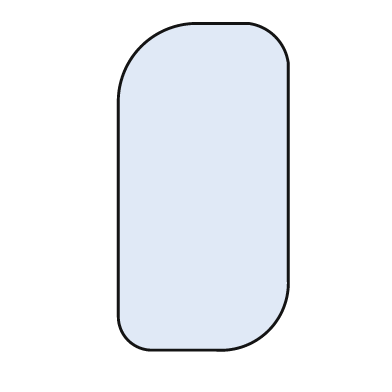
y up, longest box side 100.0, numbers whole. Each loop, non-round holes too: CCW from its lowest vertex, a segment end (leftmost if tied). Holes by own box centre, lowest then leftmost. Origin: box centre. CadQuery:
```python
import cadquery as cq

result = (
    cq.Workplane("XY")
    .moveTo(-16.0, -50.0)
    .lineTo(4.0, -50.0)
    .threePointArc((20.0, -44.0), (26.0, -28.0))
    .lineTo(26.0, 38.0)
    .threePointArc((22.0, 46.0), (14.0, 50.0))
    .lineTo(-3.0, 50.0)
    .threePointArc((-19.0, 43.0), (-26.0, 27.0))
    .lineTo(-26.0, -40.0)
    .threePointArc((-23.0, -47.0), (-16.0, -50.0))
    .close()
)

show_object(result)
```